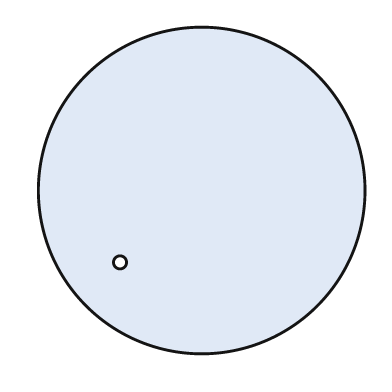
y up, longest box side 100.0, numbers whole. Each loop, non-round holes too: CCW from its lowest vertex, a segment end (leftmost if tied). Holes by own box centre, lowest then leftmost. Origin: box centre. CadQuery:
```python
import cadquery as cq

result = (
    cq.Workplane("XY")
    .moveTo(0.0, 0.0)
    .circle(50.0)
    .moveTo(-25.0, -22.0)
    .circle(2.0)
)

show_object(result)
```